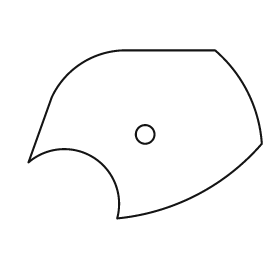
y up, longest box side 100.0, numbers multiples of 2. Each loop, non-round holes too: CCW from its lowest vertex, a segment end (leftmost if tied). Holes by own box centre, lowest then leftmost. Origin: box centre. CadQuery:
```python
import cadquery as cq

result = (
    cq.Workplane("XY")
    .moveTo(-12.0, -36.0)
    .threePointArc((22.0, -26.0), (50.0, -4.0))
    .threePointArc((44.0, 18.0), (30.0, 36.0))
    .lineTo(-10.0, 36.0)
    .threePointArc((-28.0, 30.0), (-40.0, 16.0))
    .lineTo(-50.0, -12.0)
    .threePointArc((-22.0, -10.0), (-12.0, -36.0))
    .close()
    .moveTo(0.0, 0.0)
    .circle(4.0)
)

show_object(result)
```